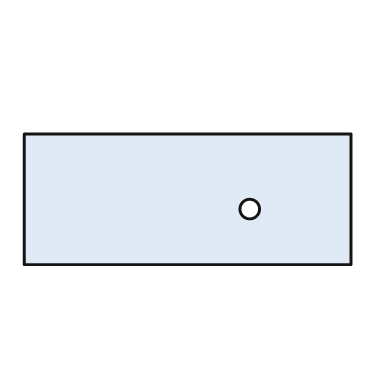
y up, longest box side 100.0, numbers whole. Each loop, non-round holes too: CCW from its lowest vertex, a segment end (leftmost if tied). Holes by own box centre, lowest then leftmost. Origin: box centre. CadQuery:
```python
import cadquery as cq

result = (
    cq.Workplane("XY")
    .moveTo(-50.0, -20.0)
    .lineTo(50.0, -20.0)
    .lineTo(50.0, 20.0)
    .lineTo(-50.0, 20.0)
    .close()
    .moveTo(19.0, -3.0)
    .circle(3.0)
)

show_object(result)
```